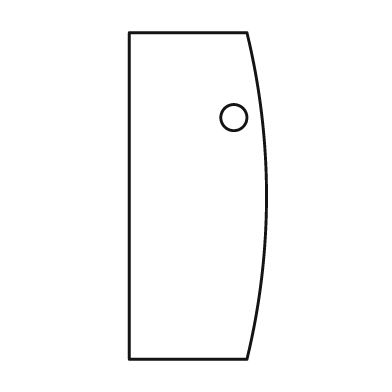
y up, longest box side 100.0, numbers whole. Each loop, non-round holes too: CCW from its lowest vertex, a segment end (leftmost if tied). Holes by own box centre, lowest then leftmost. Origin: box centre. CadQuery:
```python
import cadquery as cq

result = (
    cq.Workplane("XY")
    .moveTo(-21.0, -50.0)
    .lineTo(15.0, -50.0)
    .threePointArc((21.0, 0.0), (15.0, 50.0))
    .lineTo(-21.0, 50.0)
    .close()
    .moveTo(11.0, 24.0)
    .circle(4.0)
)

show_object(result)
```